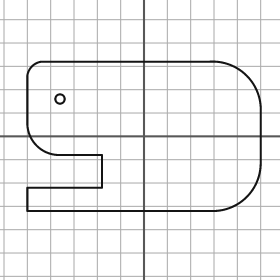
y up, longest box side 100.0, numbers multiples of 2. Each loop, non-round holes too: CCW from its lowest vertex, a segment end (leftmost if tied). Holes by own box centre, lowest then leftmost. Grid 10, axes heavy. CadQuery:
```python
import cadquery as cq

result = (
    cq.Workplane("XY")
    .moveTo(-50.0, -32.0)
    .lineTo(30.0, -32.0)
    .threePointArc((44.0, -26.0), (50.0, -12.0))
    .lineTo(50.0, 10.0)
    .threePointArc((44.0, 26.0), (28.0, 32.0))
    .lineTo(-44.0, 32.0)
    .threePointArc((-48.0, 30.0), (-50.0, 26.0))
    .lineTo(-50.0, 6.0)
    .threePointArc((-46.0, -4.0), (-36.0, -8.0))
    .lineTo(-18.0, -8.0)
    .lineTo(-18.0, -22.0)
    .lineTo(-50.0, -22.0)
    .close()
    .moveTo(-36.0, 16.0)
    .circle(2.0)
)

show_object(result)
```